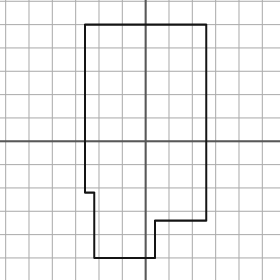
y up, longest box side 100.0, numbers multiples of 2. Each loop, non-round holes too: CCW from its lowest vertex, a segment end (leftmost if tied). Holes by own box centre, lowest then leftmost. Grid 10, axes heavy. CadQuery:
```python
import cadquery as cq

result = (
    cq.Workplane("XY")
    .moveTo(-22.0, -50.0)
    .lineTo(4.0, -50.0)
    .lineTo(4.0, -34.0)
    .lineTo(26.0, -34.0)
    .lineTo(26.0, 50.0)
    .lineTo(-26.0, 50.0)
    .lineTo(-26.0, -22.0)
    .lineTo(-22.0, -22.0)
    .close()
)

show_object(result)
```